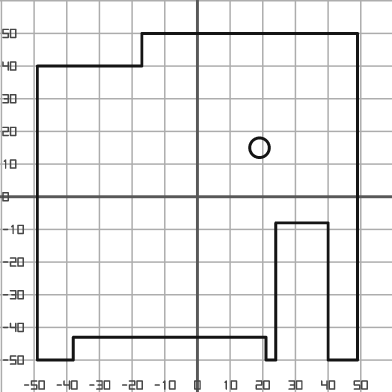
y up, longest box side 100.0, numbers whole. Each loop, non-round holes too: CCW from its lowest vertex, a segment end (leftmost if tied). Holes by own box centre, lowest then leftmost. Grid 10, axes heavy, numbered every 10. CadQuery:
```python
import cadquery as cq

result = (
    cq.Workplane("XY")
    .moveTo(-49.0, -50.0)
    .lineTo(-38.0, -50.0)
    .lineTo(-38.0, -43.0)
    .lineTo(21.0, -43.0)
    .lineTo(21.0, -50.0)
    .lineTo(24.0, -50.0)
    .lineTo(24.0, -8.0)
    .lineTo(40.0, -8.0)
    .lineTo(40.0, -50.0)
    .lineTo(49.0, -50.0)
    .lineTo(49.0, 50.0)
    .lineTo(-17.0, 50.0)
    .lineTo(-17.0, 40.0)
    .lineTo(-49.0, 40.0)
    .close()
    .moveTo(19.0, 15.0)
    .circle(3.0)
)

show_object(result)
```